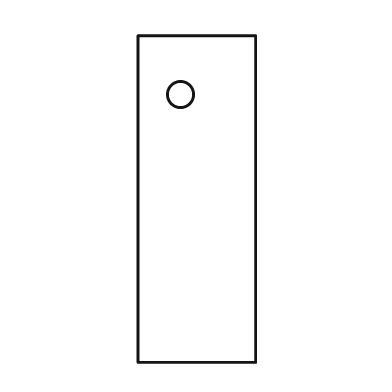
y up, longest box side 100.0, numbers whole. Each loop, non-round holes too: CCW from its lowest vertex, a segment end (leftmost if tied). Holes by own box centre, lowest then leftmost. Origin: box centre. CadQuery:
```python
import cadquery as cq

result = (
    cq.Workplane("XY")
    .moveTo(-18.0, -50.0)
    .lineTo(18.0, -50.0)
    .lineTo(18.0, 50.0)
    .lineTo(-18.0, 50.0)
    .close()
    .moveTo(-5.0, 32.0)
    .circle(4.0)
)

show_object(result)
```